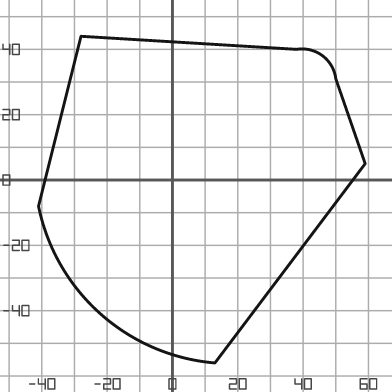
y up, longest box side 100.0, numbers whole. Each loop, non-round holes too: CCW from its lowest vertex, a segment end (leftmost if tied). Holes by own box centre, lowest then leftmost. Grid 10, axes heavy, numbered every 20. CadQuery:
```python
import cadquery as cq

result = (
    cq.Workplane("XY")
    .moveTo(13.0, -56.0)
    .lineTo(59.0, 5.0)
    .lineTo(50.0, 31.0)
    .threePointArc((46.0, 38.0), (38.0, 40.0))
    .lineTo(-28.0, 44.0)
    .lineTo(-41.0, -8.0)
    .threePointArc((-22.0, -41.0), (13.0, -56.0))
    .close()
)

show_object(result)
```